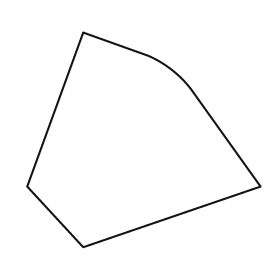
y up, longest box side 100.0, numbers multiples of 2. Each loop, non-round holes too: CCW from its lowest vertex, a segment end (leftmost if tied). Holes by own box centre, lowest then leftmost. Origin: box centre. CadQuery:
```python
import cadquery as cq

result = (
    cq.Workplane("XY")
    .moveTo(-26.0, -46.0)
    .lineTo(50.0, -20.0)
    .lineTo(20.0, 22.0)
    .threePointArc((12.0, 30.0), (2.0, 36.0))
    .lineTo(-26.0, 46.0)
    .lineTo(-50.0, -20.0)
    .close()
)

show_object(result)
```